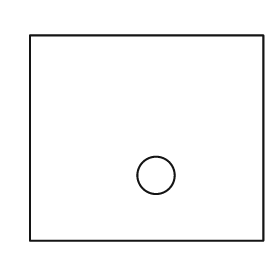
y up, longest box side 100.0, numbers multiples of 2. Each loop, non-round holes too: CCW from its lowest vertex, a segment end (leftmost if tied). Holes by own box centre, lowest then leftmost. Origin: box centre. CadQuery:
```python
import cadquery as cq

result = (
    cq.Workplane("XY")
    .moveTo(-50.0, -44.0)
    .lineTo(50.0, -44.0)
    .lineTo(50.0, 44.0)
    .lineTo(-50.0, 44.0)
    .close()
    .moveTo(4.0, -16.0)
    .circle(8.0)
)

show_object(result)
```